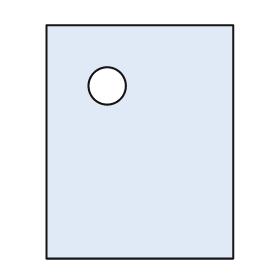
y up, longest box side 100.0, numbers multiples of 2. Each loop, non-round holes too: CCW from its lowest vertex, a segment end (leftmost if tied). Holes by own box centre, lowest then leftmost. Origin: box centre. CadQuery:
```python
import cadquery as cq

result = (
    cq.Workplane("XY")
    .moveTo(-40.0, -50.0)
    .lineTo(40.0, -50.0)
    .lineTo(40.0, 50.0)
    .lineTo(-40.0, 50.0)
    .close()
    .moveTo(-14.0, 24.0)
    .circle(8.0)
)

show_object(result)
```